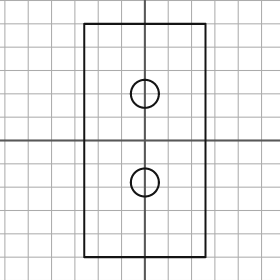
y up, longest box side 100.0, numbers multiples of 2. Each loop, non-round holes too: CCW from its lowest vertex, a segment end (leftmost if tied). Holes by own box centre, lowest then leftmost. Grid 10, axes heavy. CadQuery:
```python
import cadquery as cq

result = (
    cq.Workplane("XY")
    .moveTo(-26.0, -50.0)
    .lineTo(26.0, -50.0)
    .lineTo(26.0, 50.0)
    .lineTo(-26.0, 50.0)
    .close()
    .moveTo(0.0, -18.0)
    .circle(6.0)
    .moveTo(0.0, 20.0)
    .circle(6.0)
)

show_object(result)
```